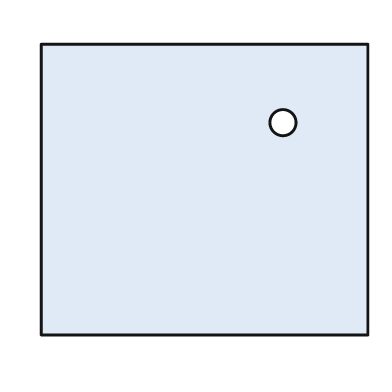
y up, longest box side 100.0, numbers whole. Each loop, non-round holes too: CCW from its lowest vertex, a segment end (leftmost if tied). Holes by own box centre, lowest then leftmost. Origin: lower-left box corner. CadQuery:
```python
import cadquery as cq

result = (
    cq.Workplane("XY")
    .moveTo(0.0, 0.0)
    .lineTo(100.0, 0.0)
    .lineTo(100.0, 89.0)
    .lineTo(0.0, 89.0)
    .close()
    .moveTo(74.0, 65.0)
    .circle(4.0)
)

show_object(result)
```